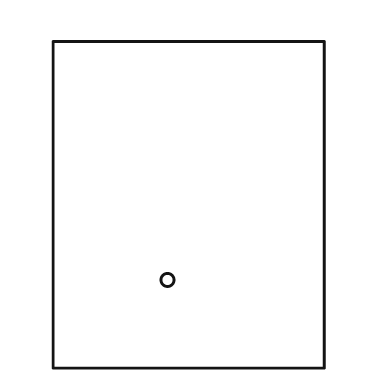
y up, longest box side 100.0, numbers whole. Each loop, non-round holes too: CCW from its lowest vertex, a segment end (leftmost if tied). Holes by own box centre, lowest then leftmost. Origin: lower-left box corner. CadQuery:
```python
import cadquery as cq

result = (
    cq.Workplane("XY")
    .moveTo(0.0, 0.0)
    .lineTo(83.0, 0.0)
    .lineTo(83.0, 100.0)
    .lineTo(0.0, 100.0)
    .close()
    .moveTo(35.0, 27.0)
    .circle(2.0)
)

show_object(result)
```